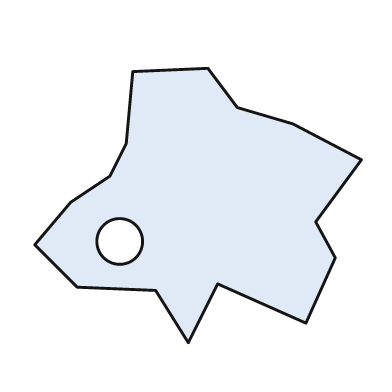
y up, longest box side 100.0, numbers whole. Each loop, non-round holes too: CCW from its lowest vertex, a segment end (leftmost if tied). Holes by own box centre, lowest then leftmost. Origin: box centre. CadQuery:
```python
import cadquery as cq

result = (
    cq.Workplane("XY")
    .moveTo(-3.0, -42.0)
    .lineTo(6.0, -24.0)
    .lineTo(33.0, -36.0)
    .lineTo(42.0, -16.0)
    .lineTo(36.0, -5.0)
    .lineTo(50.0, 14.0)
    .lineTo(29.0, 25.0)
    .lineTo(12.0, 30.0)
    .lineTo(3.0, 42.0)
    .lineTo(-20.0, 41.0)
    .lineTo(-22.0, 19.0)
    .lineTo(-27.0, 9.0)
    .lineTo(-39.0, 1.0)
    .lineTo(-50.0, -12.0)
    .lineTo(-37.0, -25.0)
    .lineTo(-13.0, -26.0)
    .close()
    .moveTo(-24.0, -11.0)
    .circle(7.0)
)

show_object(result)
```